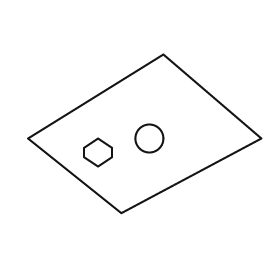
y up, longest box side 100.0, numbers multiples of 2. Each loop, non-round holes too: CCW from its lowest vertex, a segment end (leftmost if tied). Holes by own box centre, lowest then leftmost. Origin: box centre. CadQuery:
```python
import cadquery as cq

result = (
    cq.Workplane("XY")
    .moveTo(-10.0, -34.0)
    .lineTo(50.0, -2.0)
    .lineTo(8.0, 34.0)
    .lineTo(-50.0, -2.0)
    .close()
    .moveTo(-20.0, -14.0)
    .lineTo(-14.0, -10.0)
    .lineTo(-14.0, -6.0)
    .lineTo(-20.0, -2.0)
    .lineTo(-26.0, -6.0)
    .lineTo(-26.0, -10.0)
    .close()
    .moveTo(2.0, -2.0)
    .circle(6.0)
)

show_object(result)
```